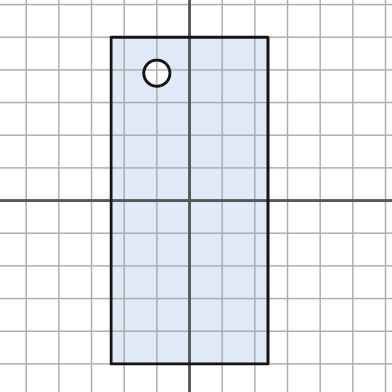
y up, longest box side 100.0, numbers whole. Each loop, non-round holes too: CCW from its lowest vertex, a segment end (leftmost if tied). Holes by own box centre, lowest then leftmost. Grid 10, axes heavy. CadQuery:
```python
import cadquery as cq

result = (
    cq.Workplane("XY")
    .moveTo(-24.0, -50.0)
    .lineTo(24.0, -50.0)
    .lineTo(24.0, 50.0)
    .lineTo(-24.0, 50.0)
    .close()
    .moveTo(-10.0, 39.0)
    .circle(4.0)
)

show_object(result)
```